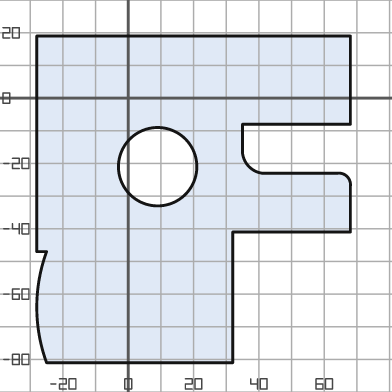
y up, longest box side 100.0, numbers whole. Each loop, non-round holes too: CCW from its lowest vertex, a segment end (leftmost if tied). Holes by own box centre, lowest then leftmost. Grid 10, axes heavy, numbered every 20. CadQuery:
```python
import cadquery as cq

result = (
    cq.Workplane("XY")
    .moveTo(-25.0, -81.0)
    .lineTo(32.0, -81.0)
    .lineTo(32.0, -41.0)
    .lineTo(68.0, -41.0)
    .lineTo(68.0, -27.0)
    .threePointArc((67.0, -24.0), (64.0, -23.0))
    .lineTo(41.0, -23.0)
    .threePointArc((37.0, -21.0), (35.0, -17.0))
    .lineTo(35.0, -8.0)
    .lineTo(68.0, -8.0)
    .lineTo(68.0, 19.0)
    .lineTo(-28.0, 19.0)
    .lineTo(-28.0, -47.0)
    .lineTo(-25.0, -47.0)
    .threePointArc((-28.0, -64.0), (-25.0, -81.0))
    .close()
    .moveTo(9.0, -21.0)
    .circle(12.0)
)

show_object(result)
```